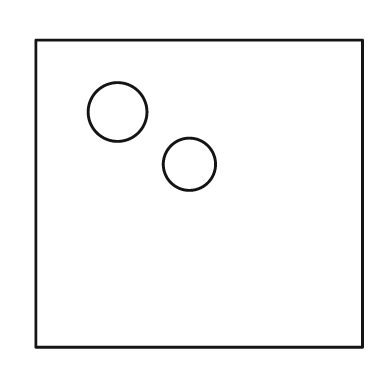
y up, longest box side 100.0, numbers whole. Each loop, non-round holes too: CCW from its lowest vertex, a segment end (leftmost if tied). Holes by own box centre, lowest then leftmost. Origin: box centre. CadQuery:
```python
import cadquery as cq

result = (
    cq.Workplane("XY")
    .moveTo(-50.0, -47.0)
    .lineTo(50.0, -47.0)
    .lineTo(50.0, 47.0)
    .lineTo(-50.0, 47.0)
    .close()
    .moveTo(-3.0, 9.0)
    .circle(8.0)
    .moveTo(-25.0, 25.0)
    .circle(9.0)
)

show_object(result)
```